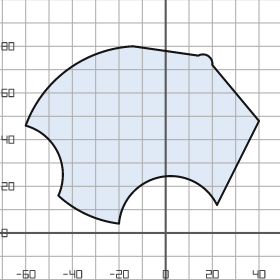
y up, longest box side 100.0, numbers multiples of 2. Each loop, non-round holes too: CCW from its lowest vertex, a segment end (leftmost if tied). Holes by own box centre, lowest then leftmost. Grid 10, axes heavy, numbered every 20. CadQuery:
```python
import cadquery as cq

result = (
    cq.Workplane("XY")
    .moveTo(-20.0, 4.0)
    .threePointArc((-2.0, 24.0), (22.0, 12.0))
    .lineTo(40.0, 48.0)
    .lineTo(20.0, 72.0)
    .threePointArc((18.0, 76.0), (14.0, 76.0))
    .lineTo(-14.0, 80.0)
    .threePointArc((-42.0, 70.0), (-60.0, 46.0))
    .threePointArc((-46.0, 34.0), (-46.0, 16.0))
    .threePointArc((-34.0, 8.0), (-20.0, 4.0))
    .close()
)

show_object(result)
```